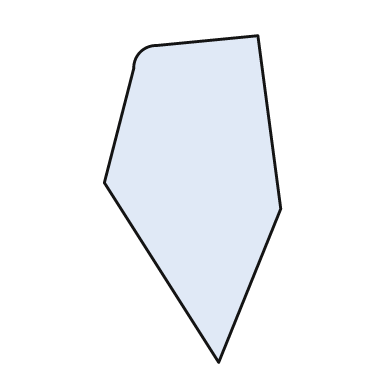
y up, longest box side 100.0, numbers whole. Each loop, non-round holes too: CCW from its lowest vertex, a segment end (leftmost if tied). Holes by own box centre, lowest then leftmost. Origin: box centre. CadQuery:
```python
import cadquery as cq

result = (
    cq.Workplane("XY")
    .moveTo(8.0, -50.0)
    .lineTo(27.0, -3.0)
    .lineTo(20.0, 50.0)
    .lineTo(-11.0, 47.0)
    .threePointArc((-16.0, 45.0), (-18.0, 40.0))
    .lineTo(-27.0, 5.0)
    .close()
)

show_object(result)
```